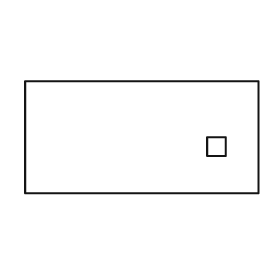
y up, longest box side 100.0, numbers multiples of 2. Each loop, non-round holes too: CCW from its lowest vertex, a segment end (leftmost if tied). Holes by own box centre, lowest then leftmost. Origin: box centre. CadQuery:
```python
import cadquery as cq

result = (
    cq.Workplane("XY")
    .moveTo(-50.0, -24.0)
    .lineTo(50.0, -24.0)
    .lineTo(50.0, 24.0)
    .lineTo(-50.0, 24.0)
    .close()
    .moveTo(28.0, -8.0)
    .lineTo(36.0, -8.0)
    .lineTo(36.0, 0.0)
    .lineTo(28.0, 0.0)
    .close()
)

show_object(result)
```